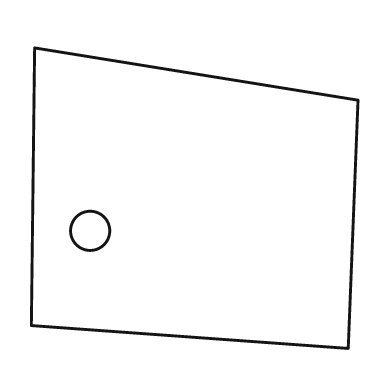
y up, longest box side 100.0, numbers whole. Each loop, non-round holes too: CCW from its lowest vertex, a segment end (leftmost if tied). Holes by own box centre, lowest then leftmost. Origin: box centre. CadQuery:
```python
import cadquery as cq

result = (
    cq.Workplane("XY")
    .moveTo(47.0, -46.0)
    .lineTo(50.0, 30.0)
    .lineTo(-49.0, 46.0)
    .lineTo(-50.0, -39.0)
    .close()
    .moveTo(-32.0, -10.0)
    .circle(6.0)
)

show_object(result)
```